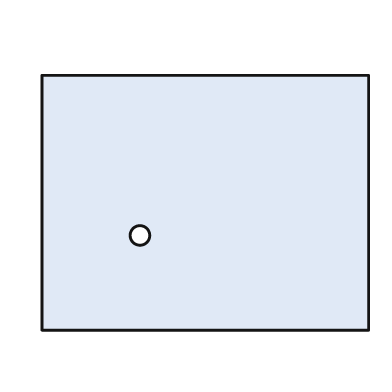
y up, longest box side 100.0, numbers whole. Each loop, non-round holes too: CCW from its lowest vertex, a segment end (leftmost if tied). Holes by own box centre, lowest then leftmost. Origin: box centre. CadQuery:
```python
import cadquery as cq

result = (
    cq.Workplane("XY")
    .moveTo(-50.0, -39.0)
    .lineTo(50.0, -39.0)
    .lineTo(50.0, 39.0)
    .lineTo(-50.0, 39.0)
    .close()
    .moveTo(-20.0, -10.0)
    .circle(3.0)
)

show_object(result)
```